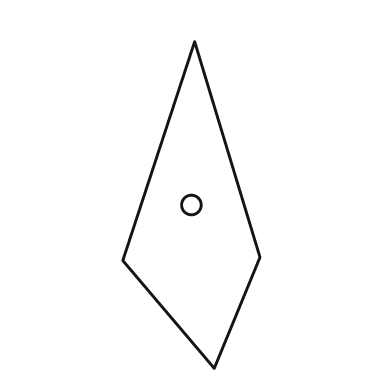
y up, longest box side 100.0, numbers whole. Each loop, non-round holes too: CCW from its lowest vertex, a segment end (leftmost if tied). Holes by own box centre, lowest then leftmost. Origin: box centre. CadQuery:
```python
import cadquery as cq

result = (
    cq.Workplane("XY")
    .moveTo(7.0, -50.0)
    .lineTo(21.0, -16.0)
    .lineTo(1.0, 50.0)
    .lineTo(-21.0, -17.0)
    .close()
    .moveTo(0.0, 0.0)
    .circle(3.0)
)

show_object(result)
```